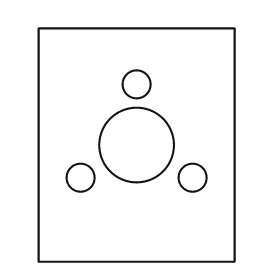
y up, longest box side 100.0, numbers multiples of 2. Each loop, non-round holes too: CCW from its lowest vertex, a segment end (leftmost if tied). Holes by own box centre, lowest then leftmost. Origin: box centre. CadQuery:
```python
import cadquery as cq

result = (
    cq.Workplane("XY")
    .moveTo(-42.0, -50.0)
    .lineTo(42.0, -50.0)
    .lineTo(42.0, 50.0)
    .lineTo(-42.0, 50.0)
    .close()
    .moveTo(-24.0, -14.0)
    .circle(6.0)
    .moveTo(24.0, -14.0)
    .circle(6.0)
    .moveTo(0.0, 0.0)
    .circle(16.0)
    .moveTo(0.0, 26.0)
    .circle(6.0)
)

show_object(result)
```